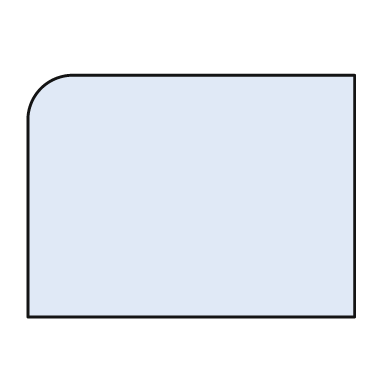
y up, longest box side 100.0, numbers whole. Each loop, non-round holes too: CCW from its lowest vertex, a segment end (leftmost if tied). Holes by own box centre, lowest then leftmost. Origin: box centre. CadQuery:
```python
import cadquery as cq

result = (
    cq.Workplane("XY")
    .moveTo(-50.0, -37.0)
    .lineTo(50.0, -37.0)
    .lineTo(50.0, 37.0)
    .lineTo(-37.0, 37.0)
    .threePointArc((-46.0, 33.0), (-50.0, 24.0))
    .close()
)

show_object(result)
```